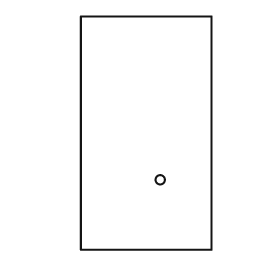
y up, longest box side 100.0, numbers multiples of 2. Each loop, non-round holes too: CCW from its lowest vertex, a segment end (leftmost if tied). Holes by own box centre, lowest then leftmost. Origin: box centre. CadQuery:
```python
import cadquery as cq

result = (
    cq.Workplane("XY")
    .moveTo(-28.0, -50.0)
    .lineTo(28.0, -50.0)
    .lineTo(28.0, 50.0)
    .lineTo(-28.0, 50.0)
    .close()
    .moveTo(6.0, -20.0)
    .circle(2.0)
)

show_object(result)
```